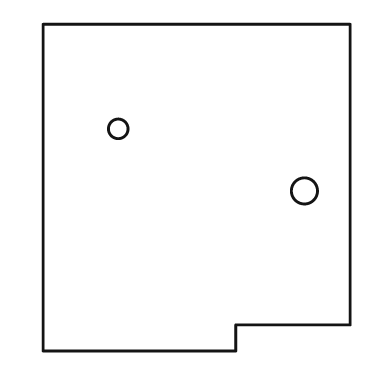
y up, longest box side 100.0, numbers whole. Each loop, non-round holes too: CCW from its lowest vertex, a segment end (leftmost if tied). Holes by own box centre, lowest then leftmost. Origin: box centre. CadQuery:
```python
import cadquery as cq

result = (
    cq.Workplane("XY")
    .moveTo(-47.0, -50.0)
    .lineTo(12.0, -50.0)
    .lineTo(12.0, -42.0)
    .lineTo(47.0, -42.0)
    .lineTo(47.0, 50.0)
    .lineTo(-47.0, 50.0)
    .close()
    .moveTo(33.0, -1.0)
    .circle(4.0)
    .moveTo(-24.0, 18.0)
    .circle(3.0)
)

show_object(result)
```